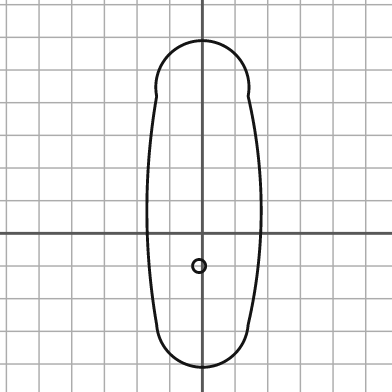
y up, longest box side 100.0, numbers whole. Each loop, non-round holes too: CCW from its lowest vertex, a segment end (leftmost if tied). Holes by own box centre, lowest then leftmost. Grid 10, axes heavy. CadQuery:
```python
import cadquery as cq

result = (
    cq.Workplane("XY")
    .moveTo(-14.0, -28.0)
    .threePointArc((0.0, -41.0), (14.0, -28.0))
    .threePointArc((18.0, 7.0), (14.0, 42.0))
    .threePointArc((0.0, 59.0), (-14.0, 42.0))
    .threePointArc((-17.0, 7.0), (-14.0, -28.0))
    .close()
    .moveTo(-1.0, -10.0)
    .circle(2.0)
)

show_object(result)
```